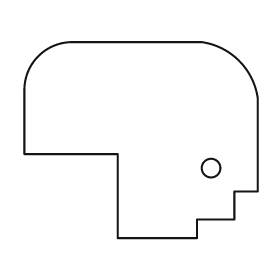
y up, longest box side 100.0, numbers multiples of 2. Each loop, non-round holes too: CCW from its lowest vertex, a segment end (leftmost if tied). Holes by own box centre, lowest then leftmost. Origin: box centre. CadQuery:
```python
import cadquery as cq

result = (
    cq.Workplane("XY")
    .moveTo(-10.0, -42.0)
    .lineTo(24.0, -42.0)
    .lineTo(24.0, -34.0)
    .lineTo(40.0, -34.0)
    .lineTo(40.0, -22.0)
    .lineTo(50.0, -22.0)
    .lineTo(50.0, 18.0)
    .threePointArc((42.0, 34.0), (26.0, 42.0))
    .lineTo(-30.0, 42.0)
    .threePointArc((-44.0, 36.0), (-50.0, 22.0))
    .lineTo(-50.0, -6.0)
    .lineTo(-10.0, -6.0)
    .close()
    .moveTo(30.0, -12.0)
    .circle(4.0)
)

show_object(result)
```